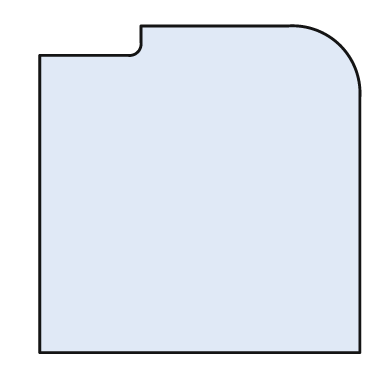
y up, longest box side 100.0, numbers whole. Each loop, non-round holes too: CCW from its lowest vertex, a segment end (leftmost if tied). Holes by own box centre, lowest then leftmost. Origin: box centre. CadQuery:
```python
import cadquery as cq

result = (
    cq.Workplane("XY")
    .moveTo(-49.0, -50.0)
    .lineTo(49.0, -50.0)
    .lineTo(49.0, 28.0)
    .threePointArc((43.0, 44.0), (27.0, 50.0))
    .lineTo(-18.0, 50.0)
    .lineTo(-18.0, 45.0)
    .threePointArc((-19.0, 42.0), (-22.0, 41.0))
    .lineTo(-49.0, 41.0)
    .close()
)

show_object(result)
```